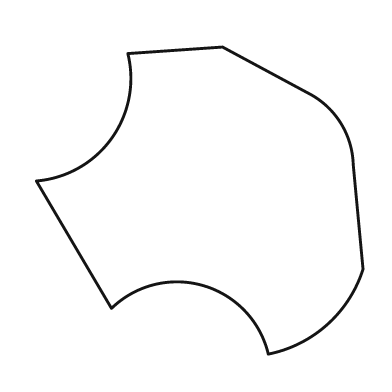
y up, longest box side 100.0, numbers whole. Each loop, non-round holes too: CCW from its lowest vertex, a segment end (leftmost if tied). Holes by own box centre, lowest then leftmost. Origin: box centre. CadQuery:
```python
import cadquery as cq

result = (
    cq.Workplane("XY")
    .moveTo(21.0, -47.0)
    .threePointArc((39.0, -38.0), (50.0, -21.0))
    .lineTo(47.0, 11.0)
    .threePointArc((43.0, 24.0), (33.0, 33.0))
    .lineTo(7.0, 47.0)
    .lineTo(-22.0, 45.0)
    .threePointArc((-27.0, 19.0), (-50.0, 6.0))
    .lineTo(-27.0, -33.0)
    .threePointArc((1.0, -26.0), (21.0, -47.0))
    .close()
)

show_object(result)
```